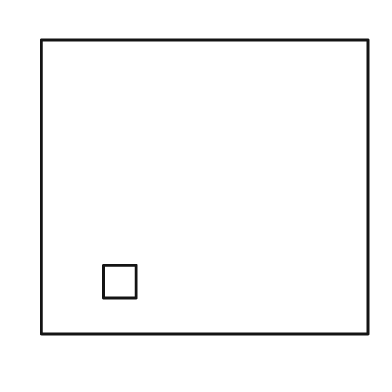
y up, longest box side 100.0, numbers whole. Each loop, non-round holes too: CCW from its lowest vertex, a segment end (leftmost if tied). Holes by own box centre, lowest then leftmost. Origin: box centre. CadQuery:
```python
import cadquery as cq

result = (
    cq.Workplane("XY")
    .moveTo(-50.0, -45.0)
    .lineTo(50.0, -45.0)
    .lineTo(50.0, 45.0)
    .lineTo(-50.0, 45.0)
    .close()
    .moveTo(-31.0, -34.0)
    .lineTo(-21.0, -34.0)
    .lineTo(-21.0, -24.0)
    .lineTo(-31.0, -24.0)
    .close()
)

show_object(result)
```